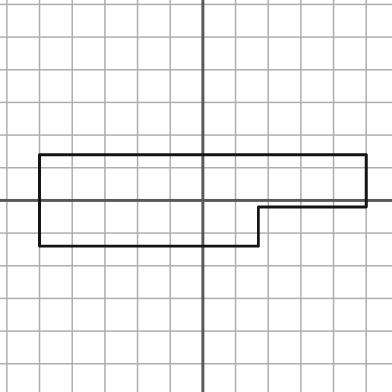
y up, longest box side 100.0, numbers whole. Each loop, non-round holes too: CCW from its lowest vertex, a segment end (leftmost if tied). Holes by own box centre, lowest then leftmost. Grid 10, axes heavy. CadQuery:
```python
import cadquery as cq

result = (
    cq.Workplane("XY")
    .moveTo(-50.0, -14.0)
    .lineTo(17.0, -14.0)
    .lineTo(17.0, -2.0)
    .lineTo(50.0, -2.0)
    .lineTo(50.0, 14.0)
    .lineTo(-50.0, 14.0)
    .close()
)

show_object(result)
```